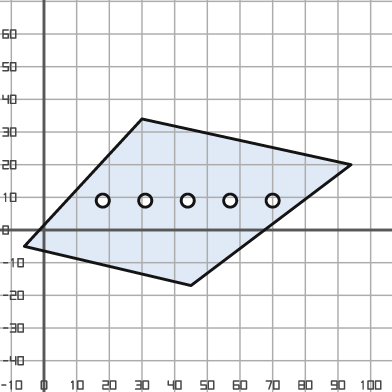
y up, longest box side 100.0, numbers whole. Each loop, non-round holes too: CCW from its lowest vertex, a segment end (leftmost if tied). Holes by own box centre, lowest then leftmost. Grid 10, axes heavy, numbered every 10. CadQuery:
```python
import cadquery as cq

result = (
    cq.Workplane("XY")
    .moveTo(45.0, -17.0)
    .lineTo(94.0, 20.0)
    .lineTo(30.0, 34.0)
    .lineTo(-6.0, -5.0)
    .close()
    .moveTo(18.0, 9.0)
    .circle(2.0)
    .moveTo(31.0, 9.0)
    .circle(2.0)
    .moveTo(44.0, 9.0)
    .circle(2.0)
    .moveTo(57.0, 9.0)
    .circle(2.0)
    .moveTo(70.0, 9.0)
    .circle(2.0)
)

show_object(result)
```